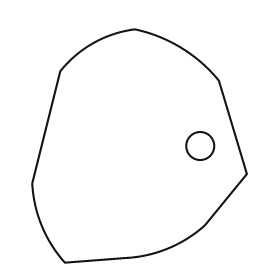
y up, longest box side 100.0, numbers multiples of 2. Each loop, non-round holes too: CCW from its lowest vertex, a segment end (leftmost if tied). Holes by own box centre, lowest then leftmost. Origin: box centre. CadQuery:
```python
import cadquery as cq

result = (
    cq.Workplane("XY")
    .moveTo(-32.0, -50.0)
    .lineTo(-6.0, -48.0)
    .threePointArc((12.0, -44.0), (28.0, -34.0))
    .lineTo(46.0, -12.0)
    .lineTo(34.0, 28.0)
    .threePointArc((18.0, 42.0), (-2.0, 50.0))
    .threePointArc((-20.0, 44.0), (-34.0, 32.0))
    .lineTo(-46.0, -16.0)
    .threePointArc((-42.0, -34.0), (-32.0, -50.0))
    .close()
    .moveTo(26.0, 0.0)
    .circle(6.0)
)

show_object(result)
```